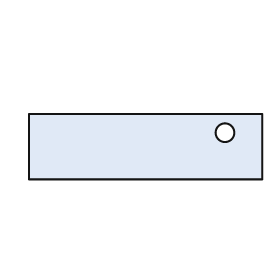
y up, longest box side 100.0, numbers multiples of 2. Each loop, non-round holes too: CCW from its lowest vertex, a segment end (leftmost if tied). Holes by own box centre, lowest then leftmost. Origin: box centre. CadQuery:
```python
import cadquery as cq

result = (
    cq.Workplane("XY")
    .moveTo(-50.0, -14.0)
    .lineTo(50.0, -14.0)
    .lineTo(50.0, 14.0)
    .lineTo(-50.0, 14.0)
    .close()
    .moveTo(34.0, 6.0)
    .circle(4.0)
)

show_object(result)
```